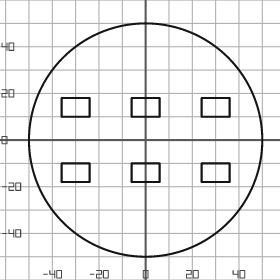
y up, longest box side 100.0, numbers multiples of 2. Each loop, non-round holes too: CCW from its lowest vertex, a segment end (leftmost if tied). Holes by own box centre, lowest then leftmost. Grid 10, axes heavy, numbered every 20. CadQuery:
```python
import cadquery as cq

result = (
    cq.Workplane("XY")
    .moveTo(0.0, 0.0)
    .circle(50.0)
    .moveTo(-36.0, -18.0)
    .lineTo(-24.0, -18.0)
    .lineTo(-24.0, -10.0)
    .lineTo(-36.0, -10.0)
    .close()
    .moveTo(-6.0, -18.0)
    .lineTo(6.0, -18.0)
    .lineTo(6.0, -10.0)
    .lineTo(-6.0, -10.0)
    .close()
    .moveTo(24.0, -18.0)
    .lineTo(36.0, -18.0)
    .lineTo(36.0, -10.0)
    .lineTo(24.0, -10.0)
    .close()
    .moveTo(-36.0, 10.0)
    .lineTo(-24.0, 10.0)
    .lineTo(-24.0, 18.0)
    .lineTo(-36.0, 18.0)
    .close()
    .moveTo(-6.0, 10.0)
    .lineTo(6.0, 10.0)
    .lineTo(6.0, 18.0)
    .lineTo(-6.0, 18.0)
    .close()
    .moveTo(24.0, 10.0)
    .lineTo(36.0, 10.0)
    .lineTo(36.0, 18.0)
    .lineTo(24.0, 18.0)
    .close()
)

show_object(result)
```